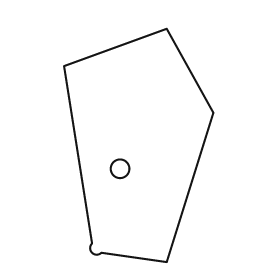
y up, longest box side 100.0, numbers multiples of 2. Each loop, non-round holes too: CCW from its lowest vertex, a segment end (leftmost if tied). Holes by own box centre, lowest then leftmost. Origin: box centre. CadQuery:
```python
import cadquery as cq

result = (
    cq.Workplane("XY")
    .moveTo(12.0, -50.0)
    .lineTo(32.0, 14.0)
    .lineTo(12.0, 50.0)
    .lineTo(-32.0, 34.0)
    .lineTo(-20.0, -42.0)
    .threePointArc((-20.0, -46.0), (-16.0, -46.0))
    .close()
    .moveTo(-8.0, -10.0)
    .circle(4.0)
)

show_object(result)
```